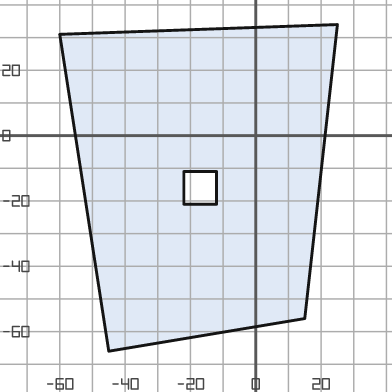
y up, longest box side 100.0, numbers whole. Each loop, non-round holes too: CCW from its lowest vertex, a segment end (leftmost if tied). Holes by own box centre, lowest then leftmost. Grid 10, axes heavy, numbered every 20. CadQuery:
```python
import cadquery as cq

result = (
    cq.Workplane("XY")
    .moveTo(-45.0, -66.0)
    .lineTo(15.0, -56.0)
    .lineTo(25.0, 34.0)
    .lineTo(-60.0, 31.0)
    .close()
    .moveTo(-22.0, -21.0)
    .lineTo(-12.0, -21.0)
    .lineTo(-12.0, -11.0)
    .lineTo(-22.0, -11.0)
    .close()
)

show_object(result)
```